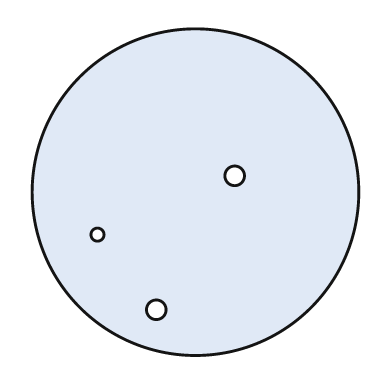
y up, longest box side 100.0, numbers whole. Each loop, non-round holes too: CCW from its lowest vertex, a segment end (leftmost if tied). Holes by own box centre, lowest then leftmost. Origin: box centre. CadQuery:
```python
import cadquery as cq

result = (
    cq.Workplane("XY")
    .moveTo(0.0, 0.0)
    .circle(50.0)
    .moveTo(-12.0, -36.0)
    .circle(3.0)
    .moveTo(-30.0, -13.0)
    .circle(2.0)
    .moveTo(12.0, 5.0)
    .circle(3.0)
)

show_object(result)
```